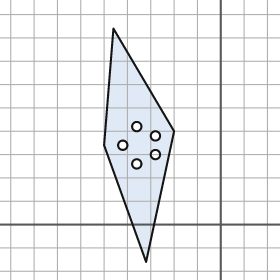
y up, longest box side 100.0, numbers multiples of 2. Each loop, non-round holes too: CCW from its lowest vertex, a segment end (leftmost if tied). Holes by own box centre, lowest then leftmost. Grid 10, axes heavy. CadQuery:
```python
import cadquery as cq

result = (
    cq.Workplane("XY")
    .moveTo(-32.0, -16.0)
    .lineTo(-20.0, 40.0)
    .lineTo(-46.0, 84.0)
    .lineTo(-50.0, 34.0)
    .close()
    .moveTo(-36.0, 26.0)
    .circle(2.0)
    .moveTo(-28.0, 30.0)
    .circle(2.0)
    .moveTo(-42.0, 34.0)
    .circle(2.0)
    .moveTo(-28.0, 38.0)
    .circle(2.0)
    .moveTo(-36.0, 42.0)
    .circle(2.0)
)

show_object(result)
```